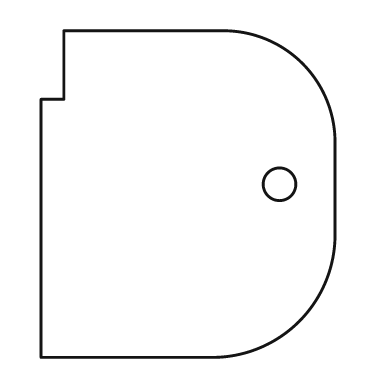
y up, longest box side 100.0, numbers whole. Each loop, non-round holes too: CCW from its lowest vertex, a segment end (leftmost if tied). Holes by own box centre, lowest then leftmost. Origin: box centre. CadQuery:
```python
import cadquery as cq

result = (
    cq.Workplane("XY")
    .moveTo(-45.0, -50.0)
    .lineTo(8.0, -50.0)
    .threePointArc((34.0, -39.0), (45.0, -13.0))
    .lineTo(45.0, 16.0)
    .threePointArc((35.0, 40.0), (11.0, 50.0))
    .lineTo(-38.0, 50.0)
    .lineTo(-38.0, 29.0)
    .lineTo(-45.0, 29.0)
    .close()
    .moveTo(28.0, 3.0)
    .circle(5.0)
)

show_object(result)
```